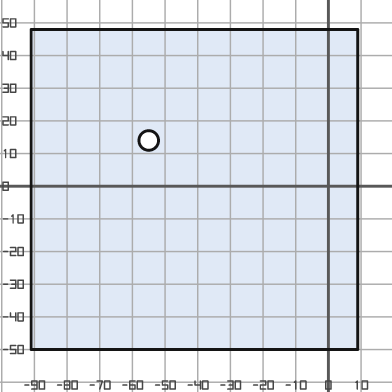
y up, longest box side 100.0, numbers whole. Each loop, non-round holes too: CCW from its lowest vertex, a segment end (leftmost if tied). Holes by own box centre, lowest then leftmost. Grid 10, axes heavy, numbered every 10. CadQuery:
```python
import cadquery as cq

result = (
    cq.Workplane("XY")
    .moveTo(-91.0, -50.0)
    .lineTo(9.0, -50.0)
    .lineTo(9.0, 48.0)
    .lineTo(-91.0, 48.0)
    .close()
    .moveTo(-55.0, 14.0)
    .circle(3.0)
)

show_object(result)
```